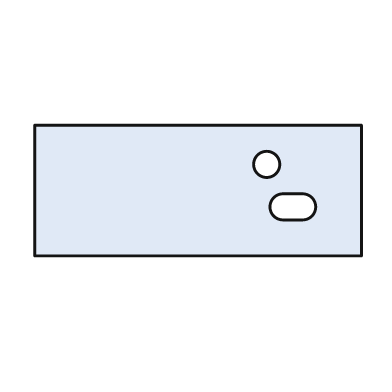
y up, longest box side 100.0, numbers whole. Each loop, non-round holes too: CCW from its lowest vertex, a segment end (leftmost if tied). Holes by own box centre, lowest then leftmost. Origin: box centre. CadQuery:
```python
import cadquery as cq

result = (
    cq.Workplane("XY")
    .moveTo(-50.0, -20.0)
    .lineTo(50.0, -20.0)
    .lineTo(50.0, 20.0)
    .lineTo(-50.0, 20.0)
    .close()
    .moveTo(26.0, -9.0)
    .lineTo(32.0, -9.0)
    .threePointArc((36.0, -5.0), (32.0, -1.0))
    .lineTo(26.0, -1.0)
    .threePointArc((22.0, -5.0), (26.0, -9.0))
    .close()
    .moveTo(21.0, 8.0)
    .circle(4.0)
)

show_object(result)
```